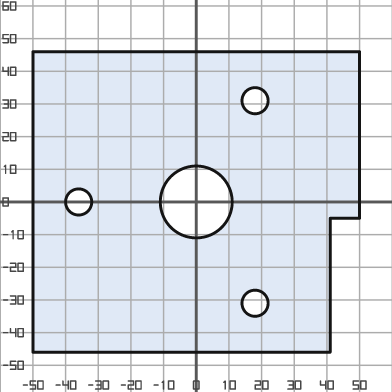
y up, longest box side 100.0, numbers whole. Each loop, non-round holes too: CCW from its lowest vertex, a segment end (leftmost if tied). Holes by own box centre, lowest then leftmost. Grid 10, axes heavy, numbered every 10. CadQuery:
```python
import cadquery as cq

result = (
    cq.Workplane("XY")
    .moveTo(-50.0, -46.0)
    .lineTo(41.0, -46.0)
    .lineTo(41.0, -5.0)
    .lineTo(50.0, -5.0)
    .lineTo(50.0, 46.0)
    .lineTo(-50.0, 46.0)
    .close()
    .moveTo(18.0, -31.0)
    .circle(4.0)
    .moveTo(-36.0, 0.0)
    .circle(4.0)
    .moveTo(0.0, 0.0)
    .circle(11.0)
    .moveTo(18.0, 31.0)
    .circle(4.0)
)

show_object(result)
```